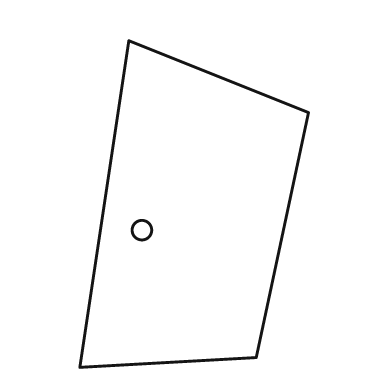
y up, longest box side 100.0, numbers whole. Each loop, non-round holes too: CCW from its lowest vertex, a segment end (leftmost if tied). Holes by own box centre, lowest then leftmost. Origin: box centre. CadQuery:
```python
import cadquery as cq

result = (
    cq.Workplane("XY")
    .moveTo(-35.0, -50.0)
    .lineTo(19.0, -47.0)
    .lineTo(35.0, 28.0)
    .lineTo(-20.0, 50.0)
    .close()
    .moveTo(-16.0, -8.0)
    .circle(3.0)
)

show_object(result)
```